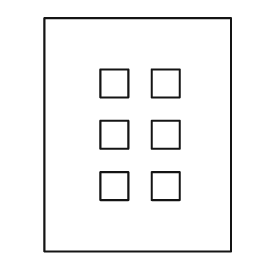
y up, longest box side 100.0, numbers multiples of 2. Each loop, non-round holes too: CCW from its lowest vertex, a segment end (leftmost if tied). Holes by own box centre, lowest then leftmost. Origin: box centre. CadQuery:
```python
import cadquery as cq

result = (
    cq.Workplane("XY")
    .moveTo(-40.0, -50.0)
    .lineTo(40.0, -50.0)
    .lineTo(40.0, 50.0)
    .lineTo(-40.0, 50.0)
    .close()
    .moveTo(-16.0, -28.0)
    .lineTo(-4.0, -28.0)
    .lineTo(-4.0, -16.0)
    .lineTo(-16.0, -16.0)
    .close()
    .moveTo(6.0, -28.0)
    .lineTo(18.0, -28.0)
    .lineTo(18.0, -16.0)
    .lineTo(6.0, -16.0)
    .close()
    .moveTo(-16.0, -6.0)
    .lineTo(-4.0, -6.0)
    .lineTo(-4.0, 6.0)
    .lineTo(-16.0, 6.0)
    .close()
    .moveTo(6.0, -6.0)
    .lineTo(18.0, -6.0)
    .lineTo(18.0, 6.0)
    .lineTo(6.0, 6.0)
    .close()
    .moveTo(-16.0, 16.0)
    .lineTo(-4.0, 16.0)
    .lineTo(-4.0, 28.0)
    .lineTo(-16.0, 28.0)
    .close()
    .moveTo(6.0, 16.0)
    .lineTo(18.0, 16.0)
    .lineTo(18.0, 28.0)
    .lineTo(6.0, 28.0)
    .close()
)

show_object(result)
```